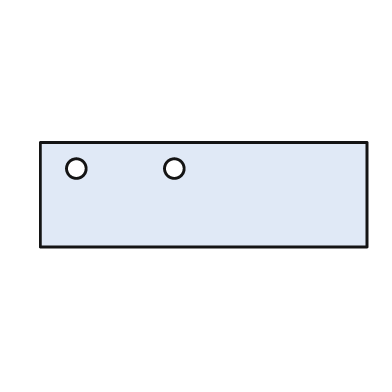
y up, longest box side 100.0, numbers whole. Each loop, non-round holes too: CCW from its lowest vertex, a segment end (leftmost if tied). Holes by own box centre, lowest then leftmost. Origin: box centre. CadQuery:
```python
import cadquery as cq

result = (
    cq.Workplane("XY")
    .moveTo(-50.0, -16.0)
    .lineTo(50.0, -16.0)
    .lineTo(50.0, 16.0)
    .lineTo(-50.0, 16.0)
    .close()
    .moveTo(-39.0, 8.0)
    .circle(3.0)
    .moveTo(-9.0, 8.0)
    .circle(3.0)
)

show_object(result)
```